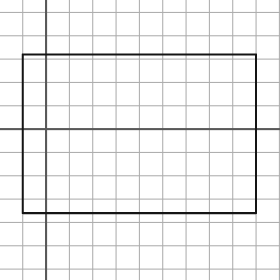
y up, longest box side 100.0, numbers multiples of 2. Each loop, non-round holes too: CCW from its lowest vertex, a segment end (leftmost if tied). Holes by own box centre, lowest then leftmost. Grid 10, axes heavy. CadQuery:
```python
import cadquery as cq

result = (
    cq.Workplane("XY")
    .moveTo(-10.0, -36.0)
    .lineTo(90.0, -36.0)
    .lineTo(90.0, 32.0)
    .lineTo(-10.0, 32.0)
    .close()
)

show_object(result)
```